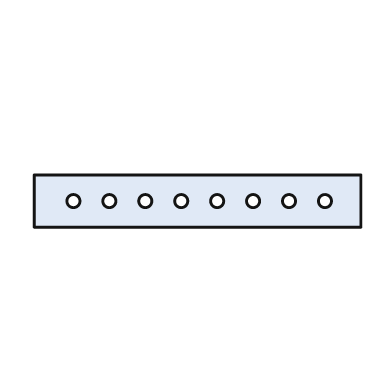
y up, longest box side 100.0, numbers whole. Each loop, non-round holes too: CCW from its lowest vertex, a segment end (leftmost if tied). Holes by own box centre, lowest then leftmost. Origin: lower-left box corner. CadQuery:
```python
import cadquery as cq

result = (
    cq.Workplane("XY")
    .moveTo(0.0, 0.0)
    .lineTo(100.0, 0.0)
    .lineTo(100.0, 16.0)
    .lineTo(0.0, 16.0)
    .close()
    .moveTo(12.0, 8.0)
    .circle(2.0)
    .moveTo(23.0, 8.0)
    .circle(2.0)
    .moveTo(34.0, 8.0)
    .circle(2.0)
    .moveTo(45.0, 8.0)
    .circle(2.0)
    .moveTo(56.0, 8.0)
    .circle(2.0)
    .moveTo(67.0, 8.0)
    .circle(2.0)
    .moveTo(78.0, 8.0)
    .circle(2.0)
    .moveTo(89.0, 8.0)
    .circle(2.0)
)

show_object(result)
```